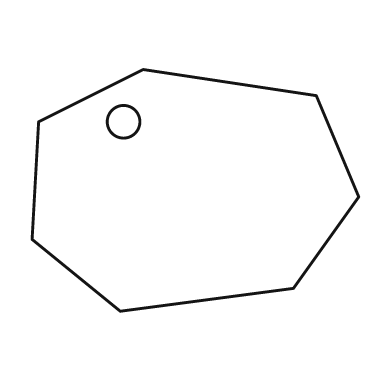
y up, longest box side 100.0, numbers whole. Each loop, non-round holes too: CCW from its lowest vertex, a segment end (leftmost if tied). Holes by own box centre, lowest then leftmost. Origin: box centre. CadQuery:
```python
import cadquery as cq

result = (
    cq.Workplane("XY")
    .moveTo(-23.0, -37.0)
    .lineTo(30.0, -30.0)
    .lineTo(50.0, -2.0)
    .lineTo(37.0, 29.0)
    .lineTo(-16.0, 37.0)
    .lineTo(-48.0, 21.0)
    .lineTo(-50.0, -15.0)
    .close()
    .moveTo(-22.0, 21.0)
    .circle(5.0)
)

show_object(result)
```